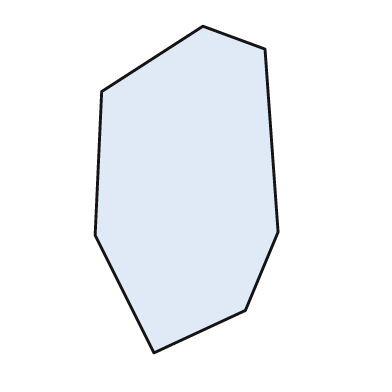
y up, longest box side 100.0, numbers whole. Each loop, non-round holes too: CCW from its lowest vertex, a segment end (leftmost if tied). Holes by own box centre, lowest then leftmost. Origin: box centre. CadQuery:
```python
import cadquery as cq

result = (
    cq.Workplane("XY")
    .moveTo(-10.0, -50.0)
    .lineTo(18.0, -37.0)
    .lineTo(28.0, -13.0)
    .lineTo(24.0, 43.0)
    .lineTo(5.0, 50.0)
    .lineTo(-26.0, 30.0)
    .lineTo(-28.0, -14.0)
    .close()
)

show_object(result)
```